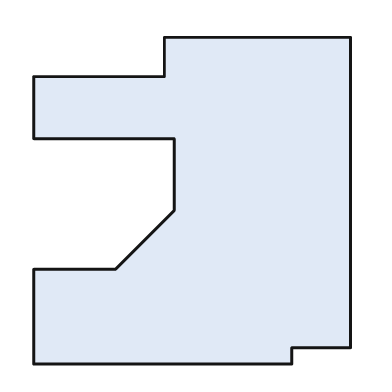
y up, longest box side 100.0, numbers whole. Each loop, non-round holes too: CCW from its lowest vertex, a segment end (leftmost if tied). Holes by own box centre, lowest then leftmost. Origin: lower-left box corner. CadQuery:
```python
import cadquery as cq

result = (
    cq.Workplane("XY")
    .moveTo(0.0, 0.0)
    .lineTo(79.0, 0.0)
    .lineTo(79.0, 5.0)
    .lineTo(97.0, 5.0)
    .lineTo(97.0, 100.0)
    .lineTo(40.0, 100.0)
    .lineTo(40.0, 88.0)
    .lineTo(0.0, 88.0)
    .lineTo(0.0, 69.0)
    .lineTo(43.0, 69.0)
    .lineTo(43.0, 47.0)
    .lineTo(25.0, 29.0)
    .lineTo(0.0, 29.0)
    .close()
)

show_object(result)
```